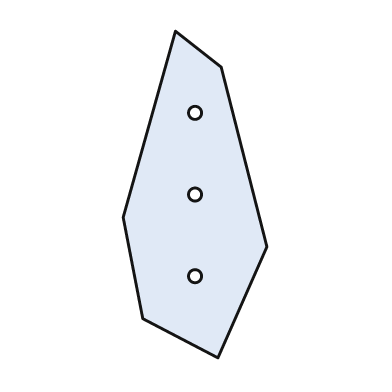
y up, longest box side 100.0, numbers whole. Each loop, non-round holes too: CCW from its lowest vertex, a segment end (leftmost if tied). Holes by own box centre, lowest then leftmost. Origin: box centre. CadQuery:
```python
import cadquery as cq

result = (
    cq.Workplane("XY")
    .moveTo(7.0, -50.0)
    .lineTo(22.0, -16.0)
    .lineTo(8.0, 39.0)
    .lineTo(-6.0, 50.0)
    .lineTo(-22.0, -7.0)
    .lineTo(-16.0, -38.0)
    .close()
    .moveTo(0.0, -25.0)
    .circle(2.0)
    .moveTo(0.0, 0.0)
    .circle(2.0)
    .moveTo(0.0, 25.0)
    .circle(2.0)
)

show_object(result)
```